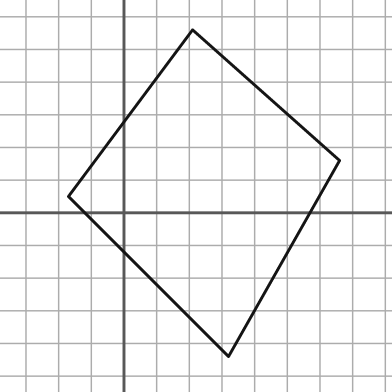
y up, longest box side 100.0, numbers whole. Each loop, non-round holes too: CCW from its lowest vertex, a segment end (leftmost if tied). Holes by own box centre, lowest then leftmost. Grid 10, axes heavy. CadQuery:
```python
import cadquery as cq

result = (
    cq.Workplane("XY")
    .moveTo(32.0, -44.0)
    .lineTo(66.0, 16.0)
    .lineTo(21.0, 56.0)
    .lineTo(-17.0, 5.0)
    .close()
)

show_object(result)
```